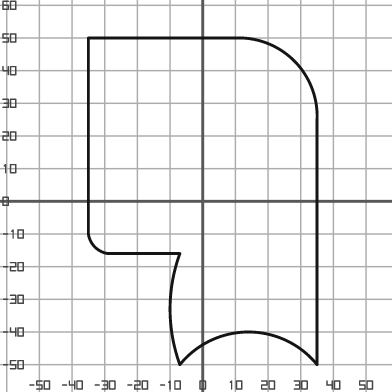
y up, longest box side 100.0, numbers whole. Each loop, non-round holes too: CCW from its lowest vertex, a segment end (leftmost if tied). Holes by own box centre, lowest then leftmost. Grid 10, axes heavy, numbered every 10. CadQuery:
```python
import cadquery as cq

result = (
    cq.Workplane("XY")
    .moveTo(-7.0, -50.0)
    .threePointArc((14.0, -40.0), (35.0, -50.0))
    .lineTo(35.0, 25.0)
    .threePointArc((28.0, 43.0), (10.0, 50.0))
    .lineTo(-35.0, 50.0)
    .lineTo(-35.0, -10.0)
    .threePointArc((-33.0, -14.0), (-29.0, -16.0))
    .lineTo(-7.0, -16.0)
    .threePointArc((-10.0, -33.0), (-7.0, -50.0))
    .close()
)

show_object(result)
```